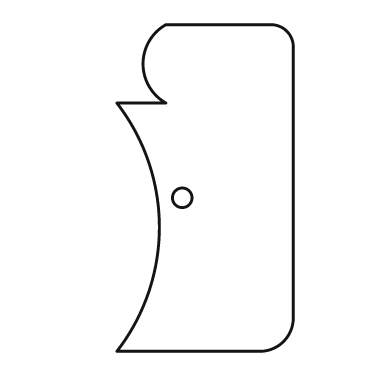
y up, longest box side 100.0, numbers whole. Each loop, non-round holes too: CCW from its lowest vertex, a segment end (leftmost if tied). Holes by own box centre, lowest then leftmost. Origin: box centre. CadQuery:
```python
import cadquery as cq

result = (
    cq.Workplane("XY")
    .moveTo(-27.0, -50.0)
    .lineTo(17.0, -50.0)
    .threePointArc((24.0, -47.0), (27.0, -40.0))
    .lineTo(27.0, 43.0)
    .threePointArc((25.0, 48.0), (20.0, 50.0))
    .lineTo(-12.0, 50.0)
    .threePointArc((-19.0, 38.0), (-12.0, 26.0))
    .lineTo(-27.0, 26.0)
    .threePointArc((-14.0, -12.0), (-27.0, -50.0))
    .close()
    .moveTo(-7.0, -3.0)
    .circle(3.0)
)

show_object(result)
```